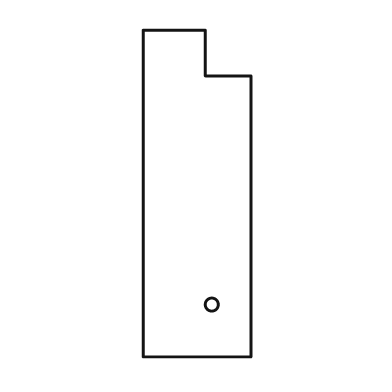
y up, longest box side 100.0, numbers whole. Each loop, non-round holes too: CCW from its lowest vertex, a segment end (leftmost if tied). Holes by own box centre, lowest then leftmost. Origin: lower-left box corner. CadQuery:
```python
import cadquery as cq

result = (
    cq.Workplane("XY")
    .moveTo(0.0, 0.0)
    .lineTo(33.0, 0.0)
    .lineTo(33.0, 86.0)
    .lineTo(19.0, 86.0)
    .lineTo(19.0, 100.0)
    .lineTo(0.0, 100.0)
    .close()
    .moveTo(21.0, 16.0)
    .circle(2.0)
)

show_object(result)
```